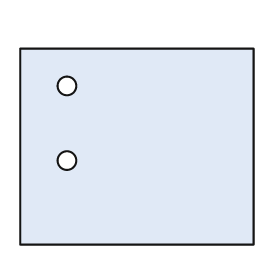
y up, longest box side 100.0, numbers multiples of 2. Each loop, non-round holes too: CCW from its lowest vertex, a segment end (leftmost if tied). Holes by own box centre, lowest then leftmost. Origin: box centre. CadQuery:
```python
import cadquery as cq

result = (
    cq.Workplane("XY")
    .moveTo(-50.0, -42.0)
    .lineTo(50.0, -42.0)
    .lineTo(50.0, 42.0)
    .lineTo(-50.0, 42.0)
    .close()
    .moveTo(-30.0, -6.0)
    .circle(4.0)
    .moveTo(-30.0, 26.0)
    .circle(4.0)
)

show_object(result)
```